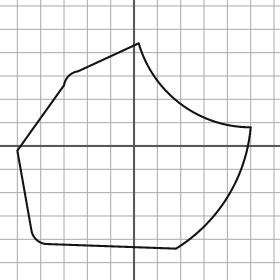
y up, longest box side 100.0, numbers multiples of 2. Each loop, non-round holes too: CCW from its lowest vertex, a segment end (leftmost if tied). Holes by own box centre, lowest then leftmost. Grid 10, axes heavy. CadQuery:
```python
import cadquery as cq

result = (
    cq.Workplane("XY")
    .moveTo(18.0, -44.0)
    .threePointArc((40.0, -22.0), (50.0, 8.0))
    .threePointArc((20.0, 18.0), (2.0, 44.0))
    .lineTo(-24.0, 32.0)
    .threePointArc((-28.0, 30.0), (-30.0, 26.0))
    .lineTo(-50.0, -2.0)
    .lineTo(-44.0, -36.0)
    .threePointArc((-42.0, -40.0), (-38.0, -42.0))
    .close()
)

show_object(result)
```